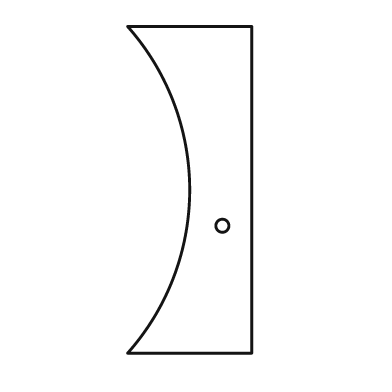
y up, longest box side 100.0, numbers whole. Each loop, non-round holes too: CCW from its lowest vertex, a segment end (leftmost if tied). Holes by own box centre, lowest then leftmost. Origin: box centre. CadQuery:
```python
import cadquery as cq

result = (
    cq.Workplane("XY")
    .moveTo(-19.0, -50.0)
    .lineTo(19.0, -50.0)
    .lineTo(19.0, 50.0)
    .lineTo(-19.0, 50.0)
    .threePointArc((0.0, 0.0), (-19.0, -50.0))
    .close()
    .moveTo(10.0, -11.0)
    .circle(2.0)
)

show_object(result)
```